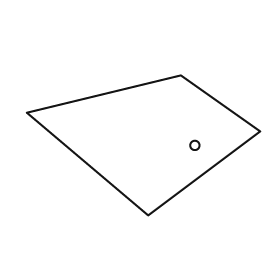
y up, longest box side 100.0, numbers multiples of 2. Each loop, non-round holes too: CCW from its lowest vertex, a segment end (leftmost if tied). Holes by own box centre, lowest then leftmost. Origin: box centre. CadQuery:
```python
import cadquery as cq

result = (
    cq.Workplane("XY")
    .moveTo(2.0, -30.0)
    .lineTo(50.0, 6.0)
    .lineTo(16.0, 30.0)
    .lineTo(-50.0, 14.0)
    .close()
    .moveTo(22.0, 0.0)
    .circle(2.0)
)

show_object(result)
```